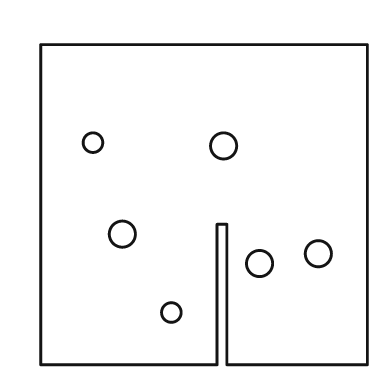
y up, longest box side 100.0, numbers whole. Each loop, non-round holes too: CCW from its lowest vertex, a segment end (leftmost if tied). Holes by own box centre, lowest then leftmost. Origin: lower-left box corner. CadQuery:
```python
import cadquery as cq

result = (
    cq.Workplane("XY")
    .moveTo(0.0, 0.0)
    .lineTo(54.0, 0.0)
    .lineTo(54.0, 43.0)
    .lineTo(57.0, 43.0)
    .lineTo(57.0, 0.0)
    .lineTo(100.0, 0.0)
    .lineTo(100.0, 98.0)
    .lineTo(0.0, 98.0)
    .close()
    .moveTo(40.0, 16.0)
    .circle(3.0)
    .moveTo(67.0, 31.0)
    .circle(4.0)
    .moveTo(85.0, 34.0)
    .circle(4.0)
    .moveTo(25.0, 40.0)
    .circle(4.0)
    .moveTo(56.0, 67.0)
    .circle(4.0)
    .moveTo(16.0, 68.0)
    .circle(3.0)
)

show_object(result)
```